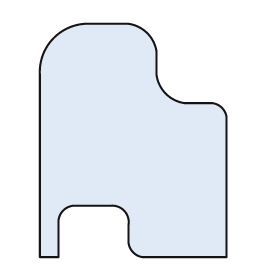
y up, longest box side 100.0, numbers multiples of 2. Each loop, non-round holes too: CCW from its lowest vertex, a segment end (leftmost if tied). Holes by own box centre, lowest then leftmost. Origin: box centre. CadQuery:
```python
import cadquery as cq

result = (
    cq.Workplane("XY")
    .moveTo(-40.0, -50.0)
    .lineTo(-32.0, -50.0)
    .lineTo(-32.0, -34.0)
    .threePointArc((-30.0, -30.0), (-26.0, -28.0))
    .lineTo(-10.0, -28.0)
    .threePointArc((-4.0, -30.0), (-2.0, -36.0))
    .lineTo(-2.0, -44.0)
    .threePointArc((0.0, -48.0), (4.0, -50.0))
    .lineTo(40.0, -50.0)
    .lineTo(40.0, 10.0)
    .threePointArc((38.0, 14.0), (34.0, 16.0))
    .lineTo(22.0, 16.0)
    .threePointArc((14.0, 20.0), (10.0, 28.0))
    .lineTo(10.0, 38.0)
    .threePointArc((6.0, 46.0), (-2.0, 50.0))
    .lineTo(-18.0, 50.0)
    .threePointArc((-34.0, 44.0), (-40.0, 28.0))
    .close()
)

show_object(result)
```